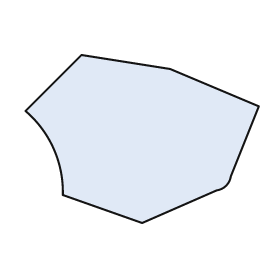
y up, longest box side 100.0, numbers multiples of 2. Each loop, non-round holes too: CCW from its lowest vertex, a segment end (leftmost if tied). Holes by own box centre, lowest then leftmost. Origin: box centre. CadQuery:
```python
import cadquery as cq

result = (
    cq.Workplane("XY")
    .moveTo(0.0, -36.0)
    .lineTo(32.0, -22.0)
    .threePointArc((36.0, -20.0), (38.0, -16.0))
    .lineTo(50.0, 14.0)
    .lineTo(12.0, 30.0)
    .lineTo(-26.0, 36.0)
    .lineTo(-50.0, 12.0)
    .threePointArc((-38.0, -4.0), (-34.0, -24.0))
    .close()
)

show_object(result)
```